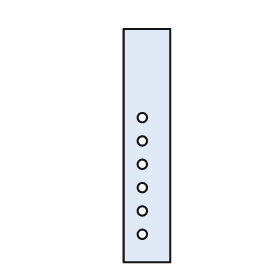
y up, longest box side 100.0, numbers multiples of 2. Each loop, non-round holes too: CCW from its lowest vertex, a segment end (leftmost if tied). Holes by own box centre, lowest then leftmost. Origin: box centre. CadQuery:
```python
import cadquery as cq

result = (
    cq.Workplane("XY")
    .moveTo(-10.0, -50.0)
    .lineTo(10.0, -50.0)
    .lineTo(10.0, 50.0)
    .lineTo(-10.0, 50.0)
    .close()
    .moveTo(-2.0, -38.0)
    .circle(2.0)
    .moveTo(-2.0, -28.0)
    .circle(2.0)
    .moveTo(-2.0, -18.0)
    .circle(2.0)
    .moveTo(-2.0, -8.0)
    .circle(2.0)
    .moveTo(-2.0, 2.0)
    .circle(2.0)
    .moveTo(-2.0, 12.0)
    .circle(2.0)
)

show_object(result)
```